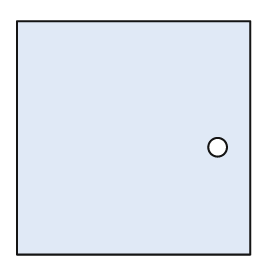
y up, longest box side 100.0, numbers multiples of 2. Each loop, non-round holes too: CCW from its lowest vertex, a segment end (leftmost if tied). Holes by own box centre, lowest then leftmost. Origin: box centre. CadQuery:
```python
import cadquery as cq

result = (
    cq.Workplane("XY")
    .moveTo(-50.0, -50.0)
    .lineTo(50.0, -50.0)
    .lineTo(50.0, 50.0)
    .lineTo(-50.0, 50.0)
    .close()
    .moveTo(36.0, -4.0)
    .circle(4.0)
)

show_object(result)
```